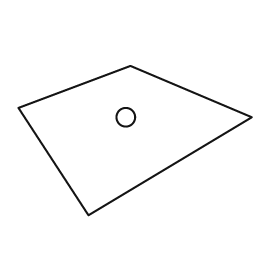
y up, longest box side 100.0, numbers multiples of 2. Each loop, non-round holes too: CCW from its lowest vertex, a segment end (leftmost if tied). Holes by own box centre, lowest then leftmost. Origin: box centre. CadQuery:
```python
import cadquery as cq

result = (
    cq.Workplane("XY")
    .moveTo(-20.0, -32.0)
    .lineTo(50.0, 10.0)
    .lineTo(-2.0, 32.0)
    .lineTo(-50.0, 14.0)
    .close()
    .moveTo(-4.0, 10.0)
    .circle(4.0)
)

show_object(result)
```